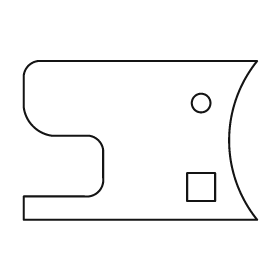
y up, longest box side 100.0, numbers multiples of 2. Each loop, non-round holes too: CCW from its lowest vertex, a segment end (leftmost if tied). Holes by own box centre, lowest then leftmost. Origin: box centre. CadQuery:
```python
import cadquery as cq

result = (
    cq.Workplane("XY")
    .moveTo(-50.0, -34.0)
    .lineTo(50.0, -34.0)
    .threePointArc((38.0, 0.0), (50.0, 34.0))
    .lineTo(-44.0, 34.0)
    .threePointArc((-48.0, 32.0), (-50.0, 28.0))
    .lineTo(-50.0, 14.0)
    .threePointArc((-46.0, 6.0), (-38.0, 2.0))
    .lineTo(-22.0, 2.0)
    .threePointArc((-18.0, 0.0), (-16.0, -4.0))
    .lineTo(-16.0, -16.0)
    .threePointArc((-18.0, -22.0), (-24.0, -24.0))
    .lineTo(-50.0, -24.0)
    .close()
    .moveTo(20.0, -26.0)
    .lineTo(32.0, -26.0)
    .lineTo(32.0, -14.0)
    .lineTo(20.0, -14.0)
    .close()
    .moveTo(26.0, 16.0)
    .circle(4.0)
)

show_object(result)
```